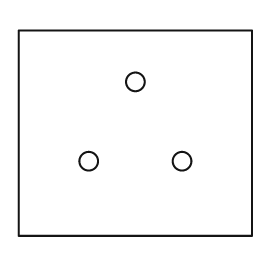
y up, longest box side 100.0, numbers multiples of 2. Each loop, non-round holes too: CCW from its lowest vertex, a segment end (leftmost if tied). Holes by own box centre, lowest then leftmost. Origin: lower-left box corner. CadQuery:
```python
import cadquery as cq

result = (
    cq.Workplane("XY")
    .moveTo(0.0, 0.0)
    .lineTo(100.0, 0.0)
    .lineTo(100.0, 88.0)
    .lineTo(0.0, 88.0)
    .close()
    .moveTo(30.0, 32.0)
    .circle(4.0)
    .moveTo(70.0, 32.0)
    .circle(4.0)
    .moveTo(50.0, 66.0)
    .circle(4.0)
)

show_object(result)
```